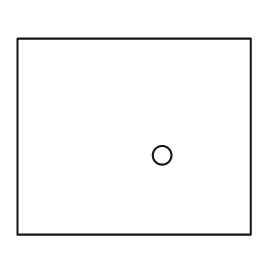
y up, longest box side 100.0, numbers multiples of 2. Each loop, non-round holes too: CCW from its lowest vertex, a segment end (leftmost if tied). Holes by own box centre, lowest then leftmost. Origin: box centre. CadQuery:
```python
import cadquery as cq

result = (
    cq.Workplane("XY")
    .moveTo(-50.0, -42.0)
    .lineTo(50.0, -42.0)
    .lineTo(50.0, 42.0)
    .lineTo(-50.0, 42.0)
    .close()
    .moveTo(12.0, -8.0)
    .circle(4.0)
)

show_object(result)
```